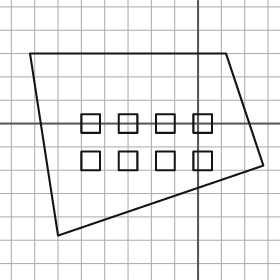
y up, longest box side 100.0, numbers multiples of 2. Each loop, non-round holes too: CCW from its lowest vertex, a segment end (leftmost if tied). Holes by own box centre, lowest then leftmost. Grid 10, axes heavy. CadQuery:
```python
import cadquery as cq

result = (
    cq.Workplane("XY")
    .moveTo(-60.0, -48.0)
    .lineTo(28.0, -18.0)
    .lineTo(12.0, 30.0)
    .lineTo(-72.0, 30.0)
    .close()
    .moveTo(-50.0, -20.0)
    .lineTo(-42.0, -20.0)
    .lineTo(-42.0, -12.0)
    .lineTo(-50.0, -12.0)
    .close()
    .moveTo(-34.0, -20.0)
    .lineTo(-26.0, -20.0)
    .lineTo(-26.0, -12.0)
    .lineTo(-34.0, -12.0)
    .close()
    .moveTo(-18.0, -20.0)
    .lineTo(-10.0, -20.0)
    .lineTo(-10.0, -12.0)
    .lineTo(-18.0, -12.0)
    .close()
    .moveTo(-2.0, -20.0)
    .lineTo(6.0, -20.0)
    .lineTo(6.0, -12.0)
    .lineTo(-2.0, -12.0)
    .close()
    .moveTo(-50.0, -4.0)
    .lineTo(-42.0, -4.0)
    .lineTo(-42.0, 4.0)
    .lineTo(-50.0, 4.0)
    .close()
    .moveTo(-34.0, -4.0)
    .lineTo(-26.0, -4.0)
    .lineTo(-26.0, 4.0)
    .lineTo(-34.0, 4.0)
    .close()
    .moveTo(-18.0, -4.0)
    .lineTo(-10.0, -4.0)
    .lineTo(-10.0, 4.0)
    .lineTo(-18.0, 4.0)
    .close()
    .moveTo(-2.0, -4.0)
    .lineTo(6.0, -4.0)
    .lineTo(6.0, 4.0)
    .lineTo(-2.0, 4.0)
    .close()
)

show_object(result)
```